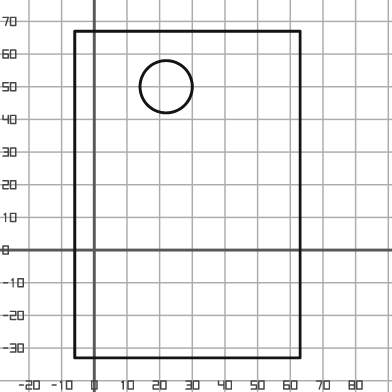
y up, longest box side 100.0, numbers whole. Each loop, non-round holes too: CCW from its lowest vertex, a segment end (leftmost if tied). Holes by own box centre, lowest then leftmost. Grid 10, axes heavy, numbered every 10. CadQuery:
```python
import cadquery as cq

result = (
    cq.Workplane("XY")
    .moveTo(-6.0, -33.0)
    .lineTo(63.0, -33.0)
    .lineTo(63.0, 67.0)
    .lineTo(-6.0, 67.0)
    .close()
    .moveTo(22.0, 50.0)
    .circle(8.0)
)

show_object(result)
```